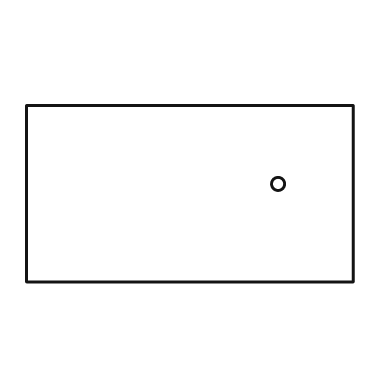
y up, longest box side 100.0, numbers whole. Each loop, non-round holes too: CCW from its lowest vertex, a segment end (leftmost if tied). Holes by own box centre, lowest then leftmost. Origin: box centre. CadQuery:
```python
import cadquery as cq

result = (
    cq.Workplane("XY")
    .moveTo(-50.0, -27.0)
    .lineTo(50.0, -27.0)
    .lineTo(50.0, 27.0)
    .lineTo(-50.0, 27.0)
    .close()
    .moveTo(27.0, 3.0)
    .circle(2.0)
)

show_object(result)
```